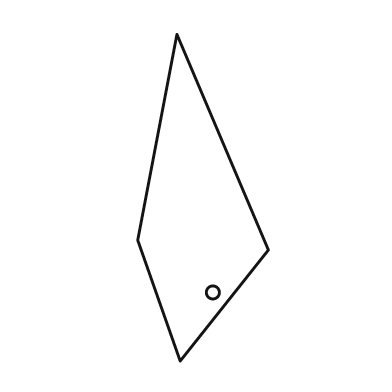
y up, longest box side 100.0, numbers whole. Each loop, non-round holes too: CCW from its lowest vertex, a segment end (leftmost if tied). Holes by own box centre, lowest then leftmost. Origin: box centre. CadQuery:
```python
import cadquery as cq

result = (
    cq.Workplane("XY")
    .moveTo(-7.0, -50.0)
    .lineTo(20.0, -16.0)
    .lineTo(-8.0, 50.0)
    .lineTo(-20.0, -13.0)
    .close()
    .moveTo(3.0, -29.0)
    .circle(2.0)
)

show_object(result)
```